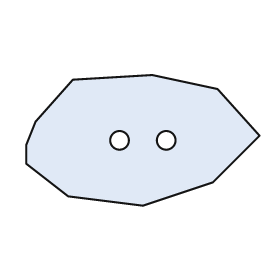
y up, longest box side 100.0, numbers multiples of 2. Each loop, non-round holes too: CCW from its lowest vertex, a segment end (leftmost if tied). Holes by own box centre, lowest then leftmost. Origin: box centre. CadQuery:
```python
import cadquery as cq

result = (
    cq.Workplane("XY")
    .moveTo(0.0, -28.0)
    .lineTo(30.0, -18.0)
    .lineTo(50.0, 2.0)
    .lineTo(32.0, 22.0)
    .lineTo(4.0, 28.0)
    .lineTo(-30.0, 26.0)
    .lineTo(-46.0, 8.0)
    .lineTo(-50.0, -2.0)
    .lineTo(-50.0, -10.0)
    .lineTo(-32.0, -24.0)
    .close()
    .moveTo(-10.0, 0.0)
    .circle(4.0)
    .moveTo(10.0, 0.0)
    .circle(4.0)
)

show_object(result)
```